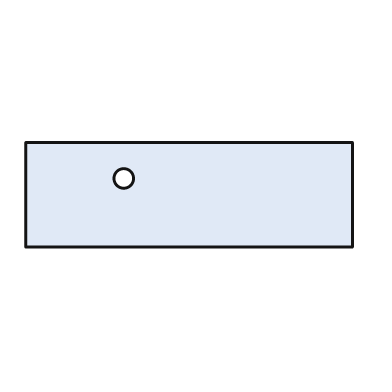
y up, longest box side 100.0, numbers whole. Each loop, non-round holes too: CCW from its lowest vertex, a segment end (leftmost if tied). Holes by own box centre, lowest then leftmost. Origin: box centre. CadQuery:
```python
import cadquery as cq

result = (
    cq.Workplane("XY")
    .moveTo(-50.0, -16.0)
    .lineTo(50.0, -16.0)
    .lineTo(50.0, 16.0)
    .lineTo(-50.0, 16.0)
    .close()
    .moveTo(-20.0, 5.0)
    .circle(3.0)
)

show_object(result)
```